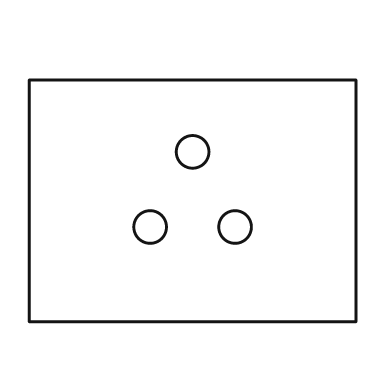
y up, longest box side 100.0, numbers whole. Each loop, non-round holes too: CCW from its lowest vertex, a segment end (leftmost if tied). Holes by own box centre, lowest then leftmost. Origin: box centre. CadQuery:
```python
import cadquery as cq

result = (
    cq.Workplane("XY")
    .moveTo(-50.0, -37.0)
    .lineTo(50.0, -37.0)
    .lineTo(50.0, 37.0)
    .lineTo(-50.0, 37.0)
    .close()
    .moveTo(-13.0, -8.0)
    .circle(5.0)
    .moveTo(13.0, -8.0)
    .circle(5.0)
    .moveTo(0.0, 15.0)
    .circle(5.0)
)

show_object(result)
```